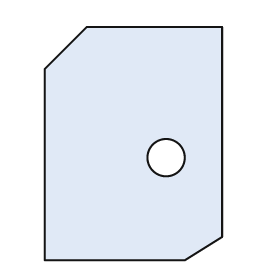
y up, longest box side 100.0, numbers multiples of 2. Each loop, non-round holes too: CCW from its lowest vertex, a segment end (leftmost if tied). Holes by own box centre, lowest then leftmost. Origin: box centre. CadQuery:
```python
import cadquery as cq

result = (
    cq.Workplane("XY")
    .moveTo(-38.0, -50.0)
    .lineTo(22.0, -50.0)
    .lineTo(38.0, -40.0)
    .lineTo(38.0, 50.0)
    .lineTo(-20.0, 50.0)
    .lineTo(-38.0, 32.0)
    .close()
    .moveTo(14.0, -6.0)
    .circle(8.0)
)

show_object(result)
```